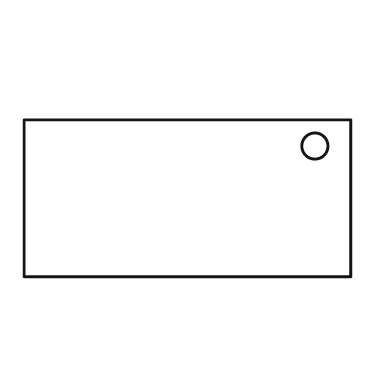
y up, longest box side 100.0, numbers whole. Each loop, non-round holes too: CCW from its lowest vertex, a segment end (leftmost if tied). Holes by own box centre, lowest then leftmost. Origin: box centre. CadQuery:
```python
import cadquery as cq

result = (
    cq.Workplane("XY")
    .moveTo(-50.0, -24.0)
    .lineTo(50.0, -24.0)
    .lineTo(50.0, 24.0)
    .lineTo(-50.0, 24.0)
    .close()
    .moveTo(39.0, 16.0)
    .circle(4.0)
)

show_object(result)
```